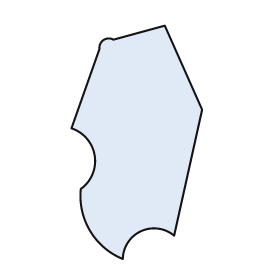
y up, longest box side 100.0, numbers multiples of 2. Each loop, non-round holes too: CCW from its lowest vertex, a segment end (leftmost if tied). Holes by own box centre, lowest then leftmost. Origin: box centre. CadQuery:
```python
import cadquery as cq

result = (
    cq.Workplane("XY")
    .moveTo(-6.0, -50.0)
    .threePointArc((2.0, -38.0), (16.0, -40.0))
    .lineTo(28.0, 14.0)
    .lineTo(12.0, 50.0)
    .lineTo(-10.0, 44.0)
    .threePointArc((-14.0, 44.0), (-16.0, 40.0))
    .lineTo(-28.0, 6.0)
    .threePointArc((-18.0, -6.0), (-24.0, -20.0))
    .threePointArc((-20.0, -38.0), (-6.0, -50.0))
    .close()
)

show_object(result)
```